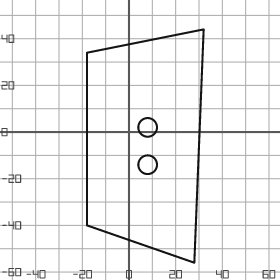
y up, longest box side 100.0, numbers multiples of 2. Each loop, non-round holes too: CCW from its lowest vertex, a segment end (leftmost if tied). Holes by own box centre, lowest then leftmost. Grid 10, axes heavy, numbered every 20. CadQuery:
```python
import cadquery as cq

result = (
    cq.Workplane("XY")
    .moveTo(28.0, -56.0)
    .lineTo(32.0, 44.0)
    .lineTo(-18.0, 34.0)
    .lineTo(-18.0, -40.0)
    .close()
    .moveTo(8.0, -14.0)
    .circle(4.0)
    .moveTo(8.0, 2.0)
    .circle(4.0)
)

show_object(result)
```